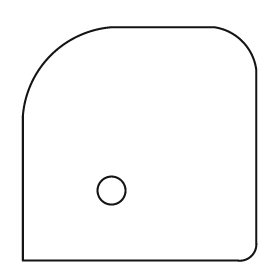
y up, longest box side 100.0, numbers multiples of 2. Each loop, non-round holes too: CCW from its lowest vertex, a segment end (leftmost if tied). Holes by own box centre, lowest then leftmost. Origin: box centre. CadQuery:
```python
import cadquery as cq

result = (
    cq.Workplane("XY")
    .moveTo(-50.0, -50.0)
    .lineTo(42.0, -50.0)
    .threePointArc((48.0, -48.0), (50.0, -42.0))
    .lineTo(50.0, 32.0)
    .threePointArc((44.0, 44.0), (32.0, 50.0))
    .lineTo(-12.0, 50.0)
    .threePointArc((-38.0, 38.0), (-50.0, 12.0))
    .close()
    .moveTo(-12.0, -20.0)
    .circle(6.0)
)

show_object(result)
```